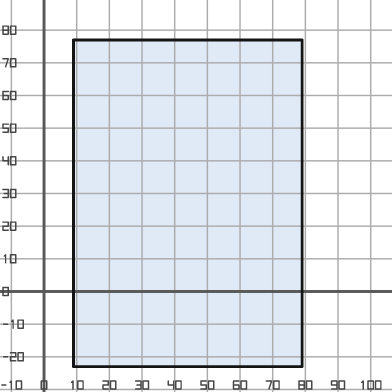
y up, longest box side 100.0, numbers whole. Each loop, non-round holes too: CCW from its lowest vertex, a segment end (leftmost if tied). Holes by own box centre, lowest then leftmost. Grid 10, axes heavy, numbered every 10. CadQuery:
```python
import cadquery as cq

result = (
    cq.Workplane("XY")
    .moveTo(9.0, -23.0)
    .lineTo(79.0, -23.0)
    .lineTo(79.0, 77.0)
    .lineTo(9.0, 77.0)
    .close()
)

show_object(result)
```